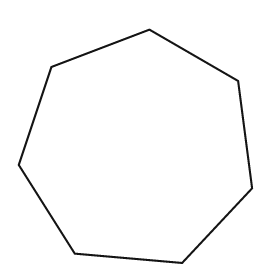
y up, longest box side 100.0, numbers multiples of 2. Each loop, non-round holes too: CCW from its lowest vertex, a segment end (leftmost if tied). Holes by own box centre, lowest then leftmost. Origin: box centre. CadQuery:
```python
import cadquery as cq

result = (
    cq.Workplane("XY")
    .moveTo(20.0, -50.0)
    .lineTo(50.0, -18.0)
    .lineTo(44.0, 28.0)
    .lineTo(6.0, 50.0)
    .lineTo(-36.0, 34.0)
    .lineTo(-50.0, -8.0)
    .lineTo(-26.0, -46.0)
    .close()
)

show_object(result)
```